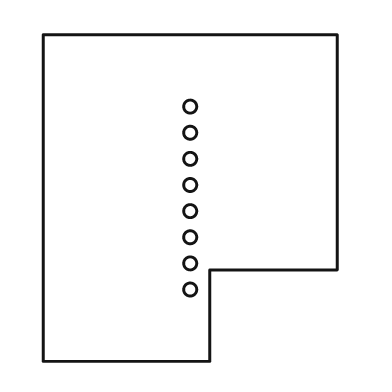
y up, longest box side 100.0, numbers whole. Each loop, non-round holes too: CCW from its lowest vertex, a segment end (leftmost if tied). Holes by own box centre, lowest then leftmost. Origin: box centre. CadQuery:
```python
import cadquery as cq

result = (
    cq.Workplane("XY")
    .moveTo(-45.0, -50.0)
    .lineTo(6.0, -50.0)
    .lineTo(6.0, -22.0)
    .lineTo(45.0, -22.0)
    .lineTo(45.0, 50.0)
    .lineTo(-45.0, 50.0)
    .close()
    .moveTo(0.0, -28.0)
    .circle(2.0)
    .moveTo(0.0, -20.0)
    .circle(2.0)
    .moveTo(0.0, -12.0)
    .circle(2.0)
    .moveTo(0.0, -4.0)
    .circle(2.0)
    .moveTo(0.0, 4.0)
    .circle(2.0)
    .moveTo(0.0, 12.0)
    .circle(2.0)
    .moveTo(0.0, 20.0)
    .circle(2.0)
    .moveTo(0.0, 28.0)
    .circle(2.0)
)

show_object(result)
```